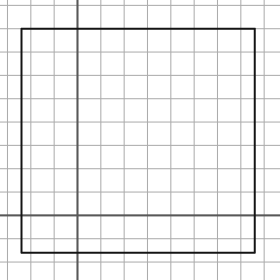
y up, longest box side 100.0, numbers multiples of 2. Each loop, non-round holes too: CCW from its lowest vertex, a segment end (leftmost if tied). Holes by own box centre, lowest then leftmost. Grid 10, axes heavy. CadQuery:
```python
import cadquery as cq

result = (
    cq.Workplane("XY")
    .moveTo(-24.0, -16.0)
    .lineTo(76.0, -16.0)
    .lineTo(76.0, 80.0)
    .lineTo(-24.0, 80.0)
    .close()
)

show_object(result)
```